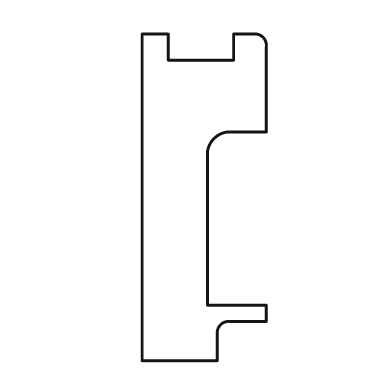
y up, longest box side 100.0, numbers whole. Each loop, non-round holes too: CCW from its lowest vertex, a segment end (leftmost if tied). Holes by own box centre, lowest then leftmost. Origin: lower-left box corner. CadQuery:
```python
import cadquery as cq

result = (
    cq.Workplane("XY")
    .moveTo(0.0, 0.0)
    .lineTo(23.0, 0.0)
    .lineTo(23.0, 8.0)
    .threePointArc((24.0, 11.0), (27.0, 12.0))
    .lineTo(38.0, 12.0)
    .lineTo(38.0, 17.0)
    .lineTo(20.0, 17.0)
    .lineTo(20.0, 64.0)
    .threePointArc((22.0, 68.0), (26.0, 70.0))
    .lineTo(38.0, 70.0)
    .lineTo(38.0, 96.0)
    .threePointArc((37.0, 99.0), (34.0, 100.0))
    .lineTo(28.0, 100.0)
    .lineTo(28.0, 92.0)
    .lineTo(8.0, 92.0)
    .lineTo(8.0, 100.0)
    .lineTo(0.0, 100.0)
    .close()
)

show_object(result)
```